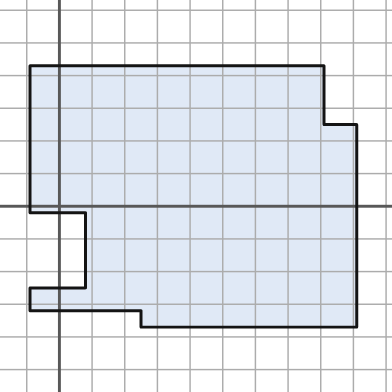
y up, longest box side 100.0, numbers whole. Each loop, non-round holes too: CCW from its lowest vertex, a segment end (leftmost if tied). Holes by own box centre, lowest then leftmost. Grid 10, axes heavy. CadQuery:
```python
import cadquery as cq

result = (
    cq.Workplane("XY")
    .moveTo(25.0, -37.0)
    .lineTo(91.0, -37.0)
    .lineTo(91.0, 25.0)
    .lineTo(81.0, 25.0)
    .lineTo(81.0, 43.0)
    .lineTo(-9.0, 43.0)
    .lineTo(-9.0, -2.0)
    .lineTo(8.0, -2.0)
    .lineTo(8.0, -25.0)
    .lineTo(-9.0, -25.0)
    .lineTo(-9.0, -32.0)
    .lineTo(25.0, -32.0)
    .close()
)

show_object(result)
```